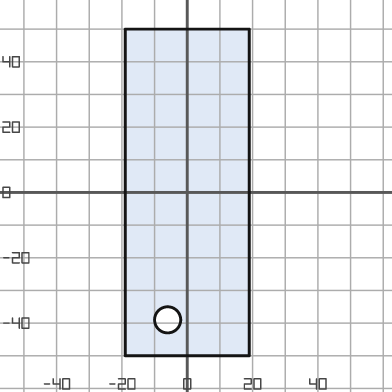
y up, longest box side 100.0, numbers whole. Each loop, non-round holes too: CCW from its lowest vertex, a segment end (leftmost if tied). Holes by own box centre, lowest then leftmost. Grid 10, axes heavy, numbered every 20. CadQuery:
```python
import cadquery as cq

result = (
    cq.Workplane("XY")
    .moveTo(-19.0, -50.0)
    .lineTo(19.0, -50.0)
    .lineTo(19.0, 50.0)
    .lineTo(-19.0, 50.0)
    .close()
    .moveTo(-6.0, -39.0)
    .circle(4.0)
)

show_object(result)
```